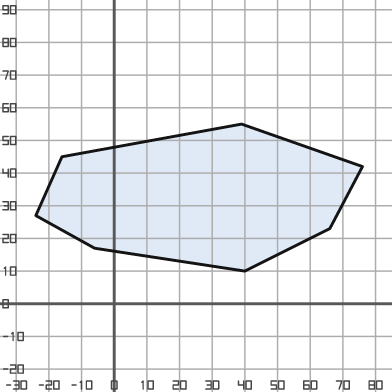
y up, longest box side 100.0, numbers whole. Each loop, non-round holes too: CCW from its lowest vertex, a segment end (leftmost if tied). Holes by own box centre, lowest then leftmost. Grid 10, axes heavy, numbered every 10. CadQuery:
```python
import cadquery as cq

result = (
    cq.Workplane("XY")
    .moveTo(40.0, 10.0)
    .lineTo(66.0, 23.0)
    .lineTo(76.0, 42.0)
    .lineTo(39.0, 55.0)
    .lineTo(-16.0, 45.0)
    .lineTo(-24.0, 27.0)
    .lineTo(-6.0, 17.0)
    .close()
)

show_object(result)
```